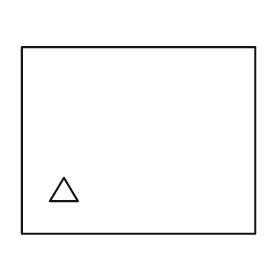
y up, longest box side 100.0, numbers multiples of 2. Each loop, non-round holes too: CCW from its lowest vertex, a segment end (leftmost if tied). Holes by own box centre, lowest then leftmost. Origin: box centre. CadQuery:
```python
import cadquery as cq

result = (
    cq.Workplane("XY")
    .moveTo(-50.0, -40.0)
    .lineTo(50.0, -40.0)
    .lineTo(50.0, 40.0)
    .lineTo(-50.0, 40.0)
    .close()
    .moveTo(-38.0, -26.0)
    .lineTo(-26.0, -26.0)
    .lineTo(-32.0, -16.0)
    .close()
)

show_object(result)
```